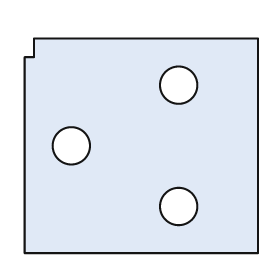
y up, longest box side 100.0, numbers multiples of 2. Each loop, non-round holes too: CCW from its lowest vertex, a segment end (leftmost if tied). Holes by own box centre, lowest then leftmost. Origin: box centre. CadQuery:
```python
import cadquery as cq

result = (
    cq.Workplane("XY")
    .moveTo(-50.0, -46.0)
    .lineTo(50.0, -46.0)
    .lineTo(50.0, 46.0)
    .lineTo(-46.0, 46.0)
    .lineTo(-46.0, 38.0)
    .lineTo(-50.0, 38.0)
    .close()
    .moveTo(16.0, -26.0)
    .circle(8.0)
    .moveTo(-30.0, 0.0)
    .circle(8.0)
    .moveTo(16.0, 26.0)
    .circle(8.0)
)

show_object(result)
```